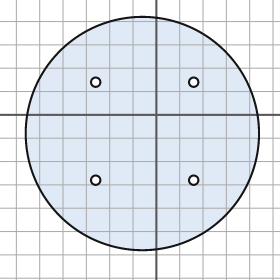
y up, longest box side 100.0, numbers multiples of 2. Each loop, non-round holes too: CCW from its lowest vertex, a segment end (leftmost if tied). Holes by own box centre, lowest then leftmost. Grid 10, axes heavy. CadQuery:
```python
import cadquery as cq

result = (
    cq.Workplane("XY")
    .moveTo(-6.0, -8.0)
    .circle(50.0)
    .moveTo(-26.0, -28.0)
    .circle(2.0)
    .moveTo(16.0, -28.0)
    .circle(2.0)
    .moveTo(-26.0, 14.0)
    .circle(2.0)
    .moveTo(16.0, 14.0)
    .circle(2.0)
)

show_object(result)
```